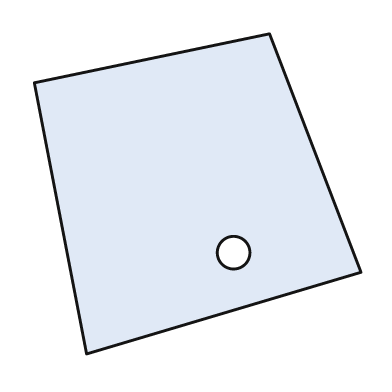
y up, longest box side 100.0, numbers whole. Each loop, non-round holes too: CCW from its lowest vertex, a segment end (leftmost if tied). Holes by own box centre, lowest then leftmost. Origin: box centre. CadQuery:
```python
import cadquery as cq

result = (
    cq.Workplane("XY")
    .moveTo(-34.0, -49.0)
    .lineTo(50.0, -24.0)
    .lineTo(22.0, 49.0)
    .lineTo(-50.0, 34.0)
    .close()
    .moveTo(11.0, -18.0)
    .circle(5.0)
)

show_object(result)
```